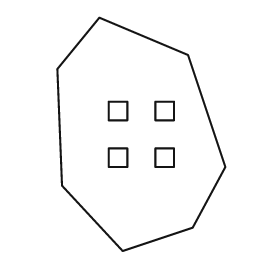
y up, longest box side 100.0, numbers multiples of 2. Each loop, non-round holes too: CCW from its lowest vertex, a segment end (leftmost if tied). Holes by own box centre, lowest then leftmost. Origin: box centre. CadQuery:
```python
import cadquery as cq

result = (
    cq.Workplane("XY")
    .moveTo(-8.0, -50.0)
    .lineTo(22.0, -40.0)
    .lineTo(36.0, -14.0)
    .lineTo(20.0, 34.0)
    .lineTo(-18.0, 50.0)
    .lineTo(-36.0, 28.0)
    .lineTo(-34.0, -22.0)
    .close()
    .moveTo(-14.0, -14.0)
    .lineTo(-6.0, -14.0)
    .lineTo(-6.0, -6.0)
    .lineTo(-14.0, -6.0)
    .close()
    .moveTo(6.0, -14.0)
    .lineTo(14.0, -14.0)
    .lineTo(14.0, -6.0)
    .lineTo(6.0, -6.0)
    .close()
    .moveTo(-14.0, 6.0)
    .lineTo(-6.0, 6.0)
    .lineTo(-6.0, 14.0)
    .lineTo(-14.0, 14.0)
    .close()
    .moveTo(6.0, 6.0)
    .lineTo(14.0, 6.0)
    .lineTo(14.0, 14.0)
    .lineTo(6.0, 14.0)
    .close()
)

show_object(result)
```